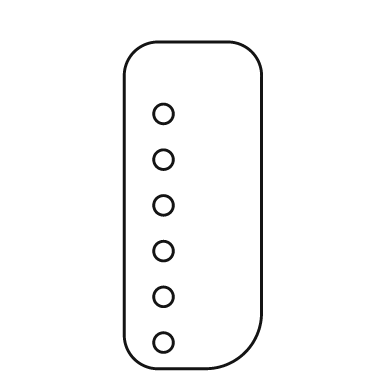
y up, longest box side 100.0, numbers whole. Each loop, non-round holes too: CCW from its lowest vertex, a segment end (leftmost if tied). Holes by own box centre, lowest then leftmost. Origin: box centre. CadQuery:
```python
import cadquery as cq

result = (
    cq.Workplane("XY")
    .moveTo(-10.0, -50.0)
    .lineTo(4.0, -50.0)
    .threePointArc((16.0, -45.0), (21.0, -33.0))
    .lineTo(21.0, 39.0)
    .threePointArc((18.0, 47.0), (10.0, 50.0))
    .lineTo(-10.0, 50.0)
    .threePointArc((-18.0, 47.0), (-21.0, 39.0))
    .lineTo(-21.0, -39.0)
    .threePointArc((-18.0, -47.0), (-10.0, -50.0))
    .close()
    .moveTo(-9.0, -42.0)
    .circle(3.0)
    .moveTo(-9.0, -28.0)
    .circle(3.0)
    .moveTo(-9.0, -14.0)
    .circle(3.0)
    .moveTo(-9.0, 0.0)
    .circle(3.0)
    .moveTo(-9.0, 14.0)
    .circle(3.0)
    .moveTo(-9.0, 28.0)
    .circle(3.0)
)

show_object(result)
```